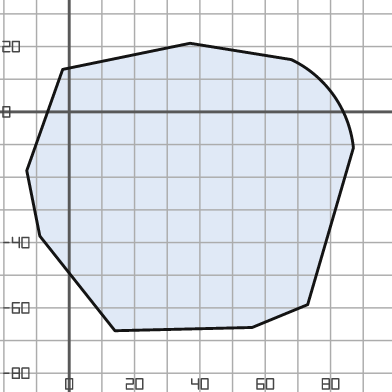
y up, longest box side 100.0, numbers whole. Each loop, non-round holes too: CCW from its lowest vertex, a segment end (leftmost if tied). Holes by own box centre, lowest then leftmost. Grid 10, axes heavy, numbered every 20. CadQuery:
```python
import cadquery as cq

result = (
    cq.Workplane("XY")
    .moveTo(14.0, -67.0)
    .lineTo(56.0, -66.0)
    .lineTo(73.0, -59.0)
    .lineTo(87.0, -11.0)
    .threePointArc((81.0, 5.0), (68.0, 16.0))
    .lineTo(37.0, 21.0)
    .lineTo(-2.0, 13.0)
    .lineTo(-13.0, -18.0)
    .lineTo(-9.0, -38.0)
    .close()
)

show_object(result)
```